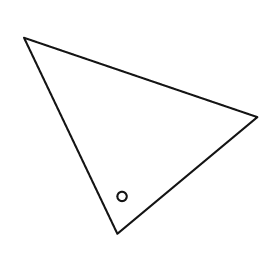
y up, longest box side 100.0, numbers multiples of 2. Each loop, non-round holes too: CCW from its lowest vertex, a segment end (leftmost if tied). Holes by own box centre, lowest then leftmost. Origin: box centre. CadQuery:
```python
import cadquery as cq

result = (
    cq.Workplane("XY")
    .moveTo(-10.0, -42.0)
    .lineTo(50.0, 8.0)
    .lineTo(-50.0, 42.0)
    .close()
    .moveTo(-8.0, -26.0)
    .circle(2.0)
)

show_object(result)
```